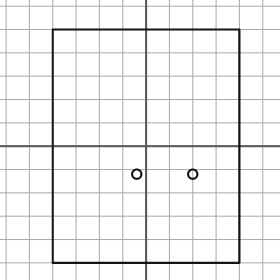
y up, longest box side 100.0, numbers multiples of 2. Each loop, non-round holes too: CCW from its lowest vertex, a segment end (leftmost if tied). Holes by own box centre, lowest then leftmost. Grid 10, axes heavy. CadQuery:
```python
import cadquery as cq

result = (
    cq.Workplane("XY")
    .moveTo(-40.0, -50.0)
    .lineTo(40.0, -50.0)
    .lineTo(40.0, 50.0)
    .lineTo(-40.0, 50.0)
    .close()
    .moveTo(-4.0, -12.0)
    .circle(2.0)
    .moveTo(20.0, -12.0)
    .circle(2.0)
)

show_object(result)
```